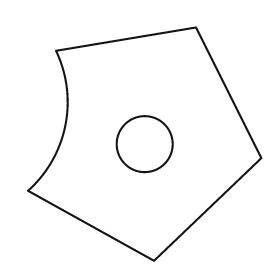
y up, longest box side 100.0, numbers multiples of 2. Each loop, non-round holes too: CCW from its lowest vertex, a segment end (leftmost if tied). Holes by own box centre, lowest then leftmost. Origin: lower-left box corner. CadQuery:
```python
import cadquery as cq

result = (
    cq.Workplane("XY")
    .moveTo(54.0, 0.0)
    .lineTo(100.0, 44.0)
    .lineTo(72.0, 100.0)
    .lineTo(12.0, 90.0)
    .threePointArc((16.0, 58.0), (0.0, 30.0))
    .close()
    .moveTo(50.0, 50.0)
    .circle(12.0)
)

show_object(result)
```